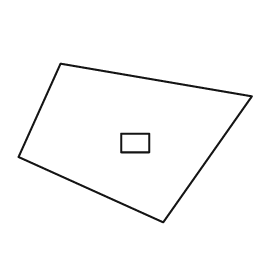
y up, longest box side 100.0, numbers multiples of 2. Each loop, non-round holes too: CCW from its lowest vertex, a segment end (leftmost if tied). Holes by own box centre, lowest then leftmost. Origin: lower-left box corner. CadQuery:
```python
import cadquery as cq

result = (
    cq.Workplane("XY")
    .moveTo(62.0, 0.0)
    .lineTo(100.0, 54.0)
    .lineTo(18.0, 68.0)
    .lineTo(0.0, 28.0)
    .close()
    .moveTo(44.0, 30.0)
    .lineTo(56.0, 30.0)
    .lineTo(56.0, 38.0)
    .lineTo(44.0, 38.0)
    .close()
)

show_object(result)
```